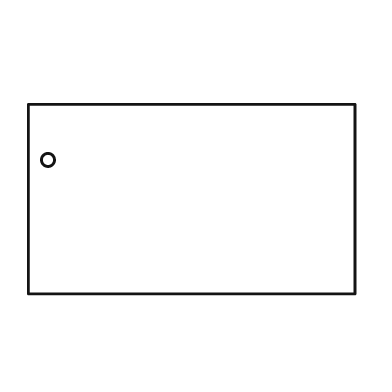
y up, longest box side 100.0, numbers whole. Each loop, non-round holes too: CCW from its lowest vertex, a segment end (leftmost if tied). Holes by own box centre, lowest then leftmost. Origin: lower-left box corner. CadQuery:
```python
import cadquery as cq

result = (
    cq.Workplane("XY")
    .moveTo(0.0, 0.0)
    .lineTo(100.0, 0.0)
    .lineTo(100.0, 58.0)
    .lineTo(0.0, 58.0)
    .close()
    .moveTo(6.0, 41.0)
    .circle(2.0)
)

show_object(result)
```